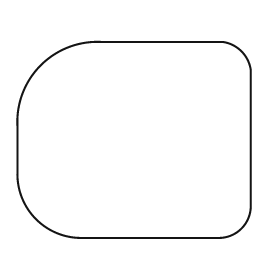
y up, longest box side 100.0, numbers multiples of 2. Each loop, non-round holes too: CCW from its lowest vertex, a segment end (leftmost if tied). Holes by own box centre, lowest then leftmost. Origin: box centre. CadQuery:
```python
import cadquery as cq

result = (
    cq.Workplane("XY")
    .moveTo(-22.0, -42.0)
    .lineTo(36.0, -42.0)
    .threePointArc((46.0, -38.0), (50.0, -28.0))
    .lineTo(50.0, 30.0)
    .threePointArc((46.0, 38.0), (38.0, 42.0))
    .lineTo(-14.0, 42.0)
    .threePointArc((-40.0, 32.0), (-50.0, 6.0))
    .lineTo(-50.0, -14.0)
    .threePointArc((-42.0, -34.0), (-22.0, -42.0))
    .close()
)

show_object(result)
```